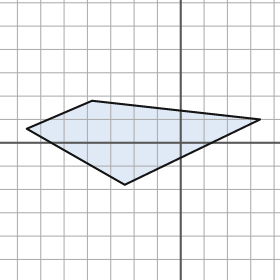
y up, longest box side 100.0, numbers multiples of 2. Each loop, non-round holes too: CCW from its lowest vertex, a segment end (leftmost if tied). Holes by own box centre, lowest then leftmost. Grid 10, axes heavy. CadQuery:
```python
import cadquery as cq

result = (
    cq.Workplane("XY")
    .moveTo(-24.0, -18.0)
    .lineTo(34.0, 10.0)
    .lineTo(-38.0, 18.0)
    .lineTo(-66.0, 6.0)
    .close()
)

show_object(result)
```